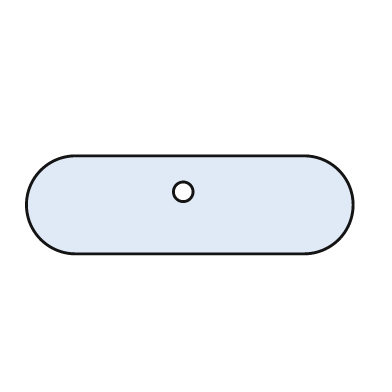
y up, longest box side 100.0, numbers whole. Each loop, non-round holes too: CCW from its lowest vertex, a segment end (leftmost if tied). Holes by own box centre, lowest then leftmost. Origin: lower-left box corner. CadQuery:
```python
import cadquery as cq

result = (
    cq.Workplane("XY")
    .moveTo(15.0, 0.0)
    .lineTo(85.0, 0.0)
    .threePointArc((100.0, 15.0), (85.0, 30.0))
    .lineTo(15.0, 30.0)
    .threePointArc((0.0, 15.0), (15.0, 0.0))
    .close()
    .moveTo(48.0, 19.0)
    .circle(3.0)
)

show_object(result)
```